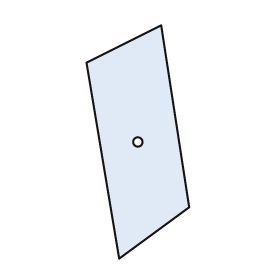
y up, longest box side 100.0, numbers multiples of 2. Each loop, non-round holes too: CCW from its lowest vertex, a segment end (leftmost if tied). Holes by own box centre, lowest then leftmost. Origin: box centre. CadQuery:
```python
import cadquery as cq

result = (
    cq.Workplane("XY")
    .moveTo(-8.0, -50.0)
    .lineTo(22.0, -28.0)
    .lineTo(10.0, 50.0)
    .lineTo(-22.0, 34.0)
    .close()
    .moveTo(0.0, 0.0)
    .circle(2.0)
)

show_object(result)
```